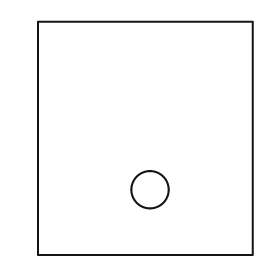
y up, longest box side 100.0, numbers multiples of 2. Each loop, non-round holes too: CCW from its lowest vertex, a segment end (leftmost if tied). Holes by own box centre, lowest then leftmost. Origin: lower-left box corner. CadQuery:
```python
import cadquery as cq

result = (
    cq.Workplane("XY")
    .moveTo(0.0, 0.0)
    .lineTo(92.0, 0.0)
    .lineTo(92.0, 100.0)
    .lineTo(0.0, 100.0)
    .close()
    .moveTo(48.0, 28.0)
    .circle(8.0)
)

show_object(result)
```